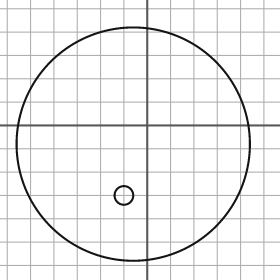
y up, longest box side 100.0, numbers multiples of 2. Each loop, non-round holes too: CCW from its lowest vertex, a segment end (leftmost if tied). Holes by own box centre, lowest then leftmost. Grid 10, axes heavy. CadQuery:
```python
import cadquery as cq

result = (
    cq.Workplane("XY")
    .moveTo(-6.0, -8.0)
    .circle(50.0)
    .moveTo(-10.0, -30.0)
    .circle(4.0)
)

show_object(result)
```